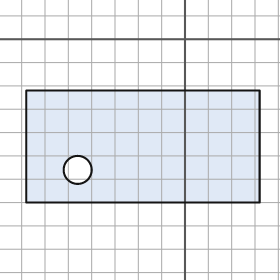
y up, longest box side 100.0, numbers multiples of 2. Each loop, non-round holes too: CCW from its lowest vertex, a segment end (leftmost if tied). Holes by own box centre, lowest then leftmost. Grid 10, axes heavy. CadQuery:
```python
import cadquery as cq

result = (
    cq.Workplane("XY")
    .moveTo(-68.0, -70.0)
    .lineTo(32.0, -70.0)
    .lineTo(32.0, -22.0)
    .lineTo(-68.0, -22.0)
    .close()
    .moveTo(-46.0, -56.0)
    .circle(6.0)
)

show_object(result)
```